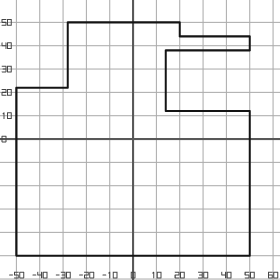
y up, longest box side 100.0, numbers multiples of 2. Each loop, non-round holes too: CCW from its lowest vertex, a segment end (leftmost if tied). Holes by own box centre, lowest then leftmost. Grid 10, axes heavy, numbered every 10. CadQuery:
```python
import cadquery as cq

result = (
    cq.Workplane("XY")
    .moveTo(-50.0, -50.0)
    .lineTo(50.0, -50.0)
    .lineTo(50.0, 12.0)
    .lineTo(14.0, 12.0)
    .lineTo(14.0, 38.0)
    .lineTo(50.0, 38.0)
    .lineTo(50.0, 44.0)
    .lineTo(20.0, 44.0)
    .lineTo(20.0, 50.0)
    .lineTo(-28.0, 50.0)
    .lineTo(-28.0, 22.0)
    .lineTo(-50.0, 22.0)
    .close()
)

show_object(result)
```